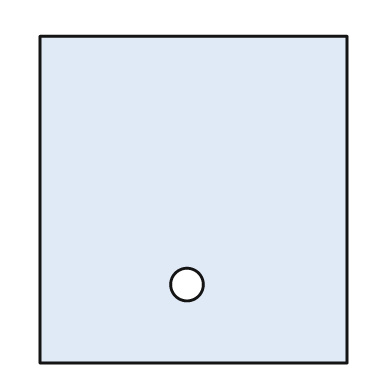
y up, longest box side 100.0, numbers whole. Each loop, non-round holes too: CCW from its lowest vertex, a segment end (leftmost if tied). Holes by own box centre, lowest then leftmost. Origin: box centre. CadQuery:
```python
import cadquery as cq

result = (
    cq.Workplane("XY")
    .moveTo(-47.0, -50.0)
    .lineTo(47.0, -50.0)
    .lineTo(47.0, 50.0)
    .lineTo(-47.0, 50.0)
    .close()
    .moveTo(-2.0, -26.0)
    .circle(5.0)
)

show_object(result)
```